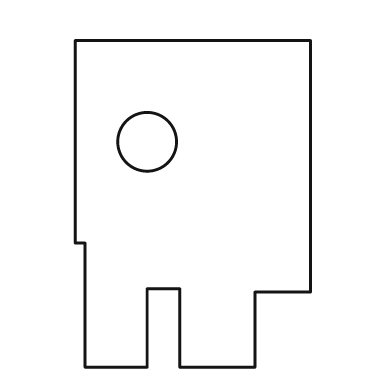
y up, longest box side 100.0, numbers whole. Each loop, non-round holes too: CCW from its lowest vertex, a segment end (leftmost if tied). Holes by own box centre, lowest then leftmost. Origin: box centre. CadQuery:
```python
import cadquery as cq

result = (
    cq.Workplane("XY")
    .moveTo(-33.0, -50.0)
    .lineTo(-14.0, -50.0)
    .lineTo(-14.0, -26.0)
    .lineTo(-4.0, -26.0)
    .lineTo(-4.0, -50.0)
    .lineTo(19.0, -50.0)
    .lineTo(19.0, -27.0)
    .lineTo(36.0, -27.0)
    .lineTo(36.0, 50.0)
    .lineTo(-36.0, 50.0)
    .lineTo(-36.0, -12.0)
    .lineTo(-33.0, -12.0)
    .close()
    .moveTo(-14.0, 19.0)
    .circle(9.0)
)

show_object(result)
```